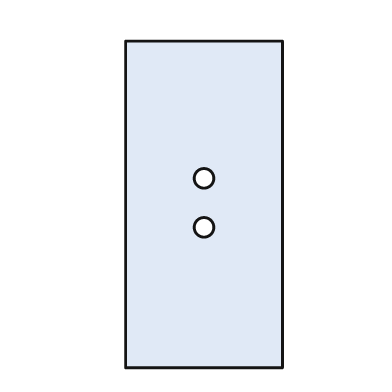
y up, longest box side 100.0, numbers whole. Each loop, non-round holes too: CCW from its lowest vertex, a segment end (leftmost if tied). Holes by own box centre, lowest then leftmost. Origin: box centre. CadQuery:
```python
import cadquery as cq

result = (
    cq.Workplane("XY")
    .moveTo(-24.0, -50.0)
    .lineTo(24.0, -50.0)
    .lineTo(24.0, 50.0)
    .lineTo(-24.0, 50.0)
    .close()
    .moveTo(0.0, -7.0)
    .circle(3.0)
    .moveTo(0.0, 8.0)
    .circle(3.0)
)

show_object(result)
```